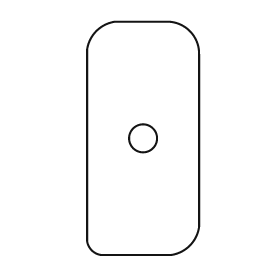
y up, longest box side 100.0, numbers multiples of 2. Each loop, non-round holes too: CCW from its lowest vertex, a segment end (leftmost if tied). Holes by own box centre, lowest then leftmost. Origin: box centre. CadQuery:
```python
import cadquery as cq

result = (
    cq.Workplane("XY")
    .moveTo(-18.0, -50.0)
    .lineTo(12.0, -50.0)
    .threePointArc((20.0, -46.0), (24.0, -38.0))
    .lineTo(24.0, 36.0)
    .threePointArc((20.0, 46.0), (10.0, 50.0))
    .lineTo(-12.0, 50.0)
    .threePointArc((-20.0, 46.0), (-24.0, 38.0))
    .lineTo(-24.0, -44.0)
    .threePointArc((-22.0, -48.0), (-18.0, -50.0))
    .close()
    .moveTo(0.0, 0.0)
    .circle(6.0)
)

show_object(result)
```